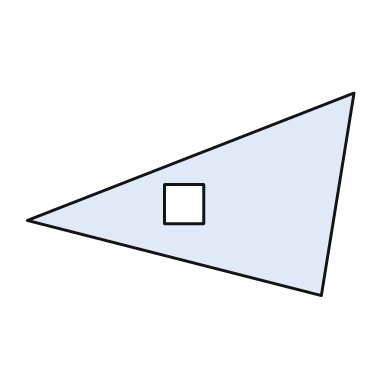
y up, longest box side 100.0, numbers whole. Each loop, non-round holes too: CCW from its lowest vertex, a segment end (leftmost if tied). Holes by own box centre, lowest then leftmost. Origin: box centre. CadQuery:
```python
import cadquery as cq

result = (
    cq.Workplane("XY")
    .moveTo(40.0, -31.0)
    .lineTo(50.0, 31.0)
    .lineTo(-50.0, -8.0)
    .close()
    .moveTo(-8.0, -9.0)
    .lineTo(4.0, -9.0)
    .lineTo(4.0, 3.0)
    .lineTo(-8.0, 3.0)
    .close()
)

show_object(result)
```